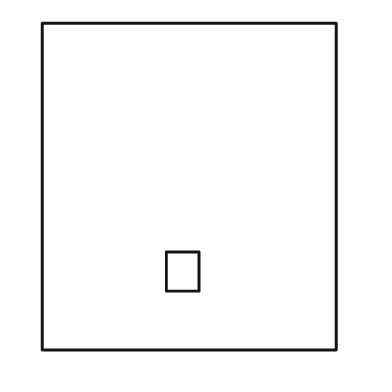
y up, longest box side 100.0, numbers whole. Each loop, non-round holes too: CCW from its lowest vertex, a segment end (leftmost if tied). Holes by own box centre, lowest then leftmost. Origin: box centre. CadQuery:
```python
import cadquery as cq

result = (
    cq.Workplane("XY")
    .moveTo(-45.0, -50.0)
    .lineTo(45.0, -50.0)
    .lineTo(45.0, 50.0)
    .lineTo(-45.0, 50.0)
    .close()
    .moveTo(-7.0, -32.0)
    .lineTo(3.0, -32.0)
    .lineTo(3.0, -20.0)
    .lineTo(-7.0, -20.0)
    .close()
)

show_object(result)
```